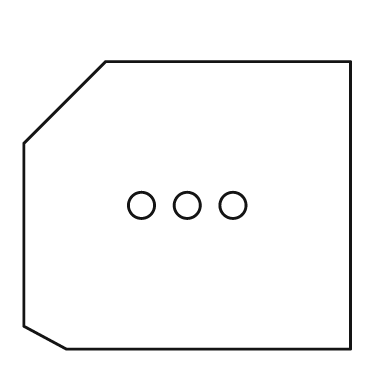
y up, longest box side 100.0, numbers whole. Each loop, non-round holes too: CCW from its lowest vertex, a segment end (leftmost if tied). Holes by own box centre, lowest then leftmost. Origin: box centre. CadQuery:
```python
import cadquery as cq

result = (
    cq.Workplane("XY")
    .moveTo(-37.0, -44.0)
    .lineTo(50.0, -44.0)
    .lineTo(50.0, 44.0)
    .lineTo(-25.0, 44.0)
    .lineTo(-50.0, 19.0)
    .lineTo(-50.0, -37.0)
    .close()
    .moveTo(-14.0, 0.0)
    .circle(4.0)
    .moveTo(0.0, 0.0)
    .circle(4.0)
    .moveTo(14.0, 0.0)
    .circle(4.0)
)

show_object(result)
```